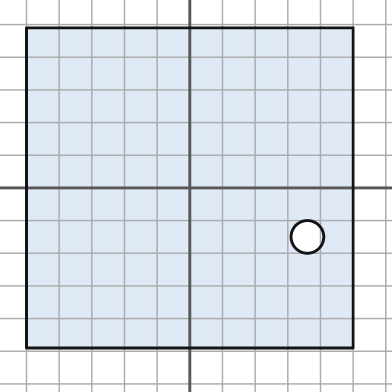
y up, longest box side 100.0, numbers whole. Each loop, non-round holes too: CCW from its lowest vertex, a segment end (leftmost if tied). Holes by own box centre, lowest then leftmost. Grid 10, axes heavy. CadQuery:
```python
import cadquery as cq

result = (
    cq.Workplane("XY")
    .moveTo(-50.0, -49.0)
    .lineTo(50.0, -49.0)
    .lineTo(50.0, 49.0)
    .lineTo(-50.0, 49.0)
    .close()
    .moveTo(36.0, -15.0)
    .circle(5.0)
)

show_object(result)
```